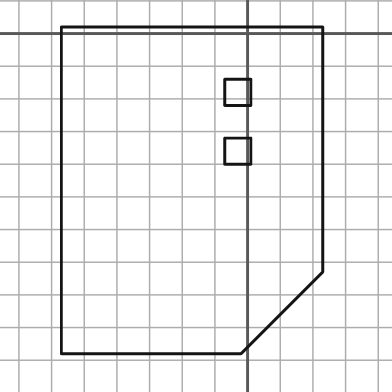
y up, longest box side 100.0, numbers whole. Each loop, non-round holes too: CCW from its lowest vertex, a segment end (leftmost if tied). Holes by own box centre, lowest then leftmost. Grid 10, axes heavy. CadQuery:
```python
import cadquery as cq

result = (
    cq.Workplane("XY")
    .moveTo(-57.0, -98.0)
    .lineTo(-2.0, -98.0)
    .lineTo(23.0, -73.0)
    .lineTo(23.0, 2.0)
    .lineTo(-57.0, 2.0)
    .close()
    .moveTo(-7.0, -40.0)
    .lineTo(1.0, -40.0)
    .lineTo(1.0, -32.0)
    .lineTo(-7.0, -32.0)
    .close()
    .moveTo(-7.0, -22.0)
    .lineTo(1.0, -22.0)
    .lineTo(1.0, -14.0)
    .lineTo(-7.0, -14.0)
    .close()
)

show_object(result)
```